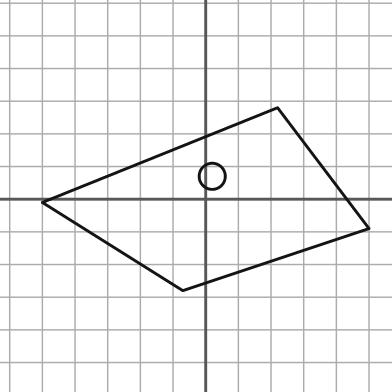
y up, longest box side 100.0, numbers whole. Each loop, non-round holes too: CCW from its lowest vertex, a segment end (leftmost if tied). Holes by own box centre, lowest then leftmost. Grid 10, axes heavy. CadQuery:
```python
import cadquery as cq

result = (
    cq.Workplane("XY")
    .moveTo(-7.0, -28.0)
    .lineTo(50.0, -9.0)
    .lineTo(22.0, 28.0)
    .lineTo(-50.0, -1.0)
    .close()
    .moveTo(2.0, 7.0)
    .circle(4.0)
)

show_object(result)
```